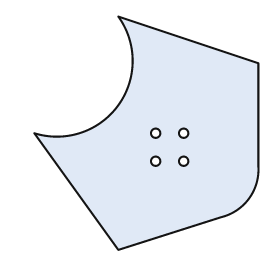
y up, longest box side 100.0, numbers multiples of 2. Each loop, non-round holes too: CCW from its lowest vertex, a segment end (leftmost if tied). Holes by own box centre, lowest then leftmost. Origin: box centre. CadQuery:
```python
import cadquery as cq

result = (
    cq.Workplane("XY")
    .moveTo(-12.0, -50.0)
    .lineTo(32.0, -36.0)
    .threePointArc((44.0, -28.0), (48.0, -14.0))
    .lineTo(48.0, 30.0)
    .lineTo(-12.0, 50.0)
    .threePointArc((-12.0, 12.0), (-48.0, 0.0))
    .close()
    .moveTo(4.0, -12.0)
    .circle(2.0)
    .moveTo(16.0, -12.0)
    .circle(2.0)
    .moveTo(4.0, 0.0)
    .circle(2.0)
    .moveTo(16.0, 0.0)
    .circle(2.0)
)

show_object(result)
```